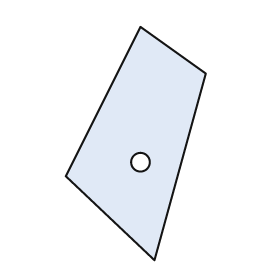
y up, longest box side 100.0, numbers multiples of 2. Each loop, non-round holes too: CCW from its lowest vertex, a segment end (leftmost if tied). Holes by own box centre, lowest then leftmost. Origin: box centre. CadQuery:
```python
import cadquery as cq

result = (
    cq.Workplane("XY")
    .moveTo(8.0, -50.0)
    .lineTo(30.0, 30.0)
    .lineTo(2.0, 50.0)
    .lineTo(-30.0, -14.0)
    .close()
    .moveTo(2.0, -8.0)
    .circle(4.0)
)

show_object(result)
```